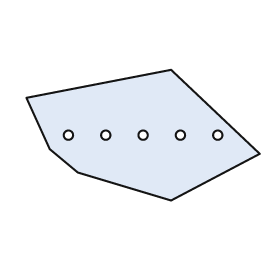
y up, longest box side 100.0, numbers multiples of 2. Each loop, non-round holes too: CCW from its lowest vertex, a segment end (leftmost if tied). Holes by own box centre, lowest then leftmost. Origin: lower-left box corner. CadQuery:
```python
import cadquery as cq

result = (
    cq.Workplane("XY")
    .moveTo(62.0, 0.0)
    .lineTo(100.0, 20.0)
    .lineTo(62.0, 56.0)
    .lineTo(0.0, 44.0)
    .lineTo(10.0, 22.0)
    .lineTo(22.0, 12.0)
    .close()
    .moveTo(18.0, 28.0)
    .circle(2.0)
    .moveTo(34.0, 28.0)
    .circle(2.0)
    .moveTo(50.0, 28.0)
    .circle(2.0)
    .moveTo(66.0, 28.0)
    .circle(2.0)
    .moveTo(82.0, 28.0)
    .circle(2.0)
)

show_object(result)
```